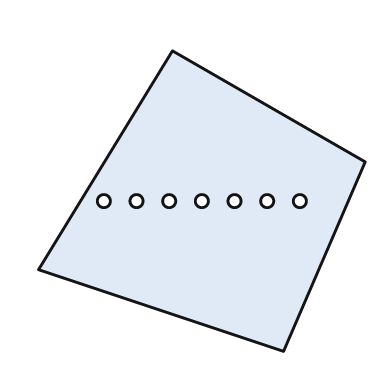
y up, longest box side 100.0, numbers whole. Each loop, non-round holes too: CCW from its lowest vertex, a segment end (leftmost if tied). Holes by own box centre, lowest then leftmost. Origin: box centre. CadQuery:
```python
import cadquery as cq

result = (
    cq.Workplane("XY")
    .moveTo(25.0, -46.0)
    .lineTo(50.0, 12.0)
    .lineTo(-9.0, 46.0)
    .lineTo(-50.0, -21.0)
    .close()
    .moveTo(-30.0, 0.0)
    .circle(2.0)
    .moveTo(-20.0, 0.0)
    .circle(2.0)
    .moveTo(-10.0, 0.0)
    .circle(2.0)
    .moveTo(0.0, 0.0)
    .circle(2.0)
    .moveTo(10.0, 0.0)
    .circle(2.0)
    .moveTo(20.0, 0.0)
    .circle(2.0)
    .moveTo(30.0, 0.0)
    .circle(2.0)
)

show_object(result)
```